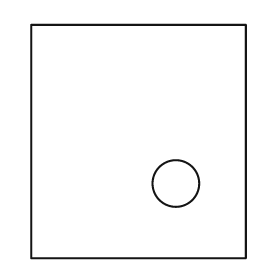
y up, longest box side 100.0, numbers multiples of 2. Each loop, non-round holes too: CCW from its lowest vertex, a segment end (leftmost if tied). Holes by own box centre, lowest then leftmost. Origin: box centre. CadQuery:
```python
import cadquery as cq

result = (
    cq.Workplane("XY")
    .moveTo(-46.0, -50.0)
    .lineTo(46.0, -50.0)
    .lineTo(46.0, 50.0)
    .lineTo(-46.0, 50.0)
    .close()
    .moveTo(16.0, -18.0)
    .circle(10.0)
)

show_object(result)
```